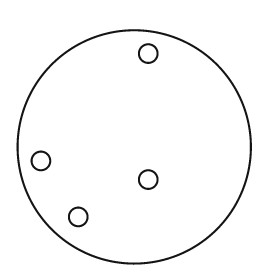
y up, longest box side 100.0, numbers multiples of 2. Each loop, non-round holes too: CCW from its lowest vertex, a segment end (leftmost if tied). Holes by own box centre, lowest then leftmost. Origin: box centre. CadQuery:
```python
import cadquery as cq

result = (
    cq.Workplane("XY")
    .moveTo(0.0, 0.0)
    .circle(50.0)
    .moveTo(-24.0, -30.0)
    .circle(4.0)
    .moveTo(6.0, -14.0)
    .circle(4.0)
    .moveTo(-40.0, -6.0)
    .circle(4.0)
    .moveTo(6.0, 40.0)
    .circle(4.0)
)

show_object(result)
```